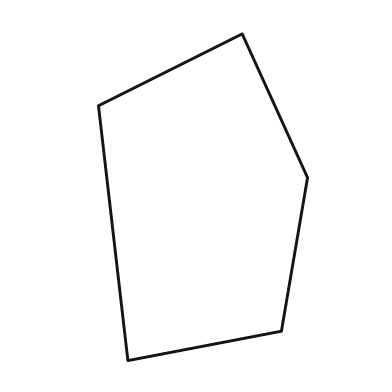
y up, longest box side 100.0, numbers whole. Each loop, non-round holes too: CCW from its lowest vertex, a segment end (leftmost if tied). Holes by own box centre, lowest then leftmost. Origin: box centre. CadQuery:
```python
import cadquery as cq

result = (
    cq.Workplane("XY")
    .moveTo(-23.0, -50.0)
    .lineTo(24.0, -41.0)
    .lineTo(32.0, 6.0)
    .lineTo(12.0, 50.0)
    .lineTo(-32.0, 28.0)
    .close()
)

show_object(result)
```